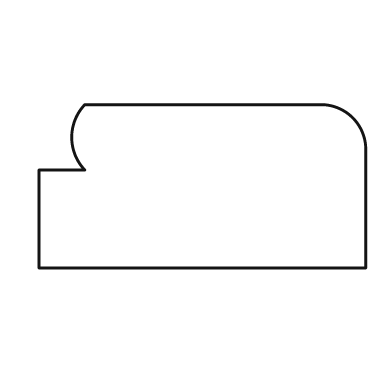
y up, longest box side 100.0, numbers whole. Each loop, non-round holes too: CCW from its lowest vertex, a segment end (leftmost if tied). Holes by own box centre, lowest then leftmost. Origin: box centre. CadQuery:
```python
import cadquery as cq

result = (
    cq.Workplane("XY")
    .moveTo(-50.0, -25.0)
    .lineTo(50.0, -25.0)
    .lineTo(50.0, 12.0)
    .threePointArc((46.0, 21.0), (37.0, 25.0))
    .lineTo(-36.0, 25.0)
    .threePointArc((-40.0, 15.0), (-36.0, 5.0))
    .lineTo(-50.0, 5.0)
    .close()
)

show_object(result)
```